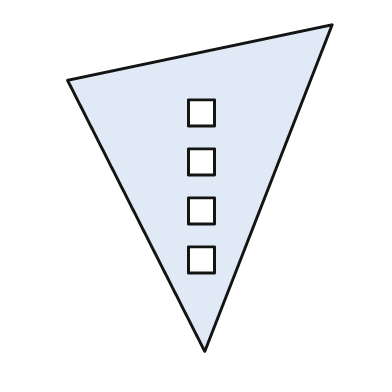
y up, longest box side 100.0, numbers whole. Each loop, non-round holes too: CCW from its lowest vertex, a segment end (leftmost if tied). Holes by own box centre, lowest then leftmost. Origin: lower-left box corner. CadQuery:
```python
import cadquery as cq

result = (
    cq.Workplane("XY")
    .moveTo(42.0, 0.0)
    .lineTo(81.0, 100.0)
    .lineTo(0.0, 83.0)
    .close()
    .moveTo(37.0, 24.0)
    .lineTo(45.0, 24.0)
    .lineTo(45.0, 32.0)
    .lineTo(37.0, 32.0)
    .close()
    .moveTo(37.0, 39.0)
    .lineTo(45.0, 39.0)
    .lineTo(45.0, 47.0)
    .lineTo(37.0, 47.0)
    .close()
    .moveTo(37.0, 54.0)
    .lineTo(45.0, 54.0)
    .lineTo(45.0, 62.0)
    .lineTo(37.0, 62.0)
    .close()
    .moveTo(37.0, 69.0)
    .lineTo(45.0, 69.0)
    .lineTo(45.0, 77.0)
    .lineTo(37.0, 77.0)
    .close()
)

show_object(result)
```